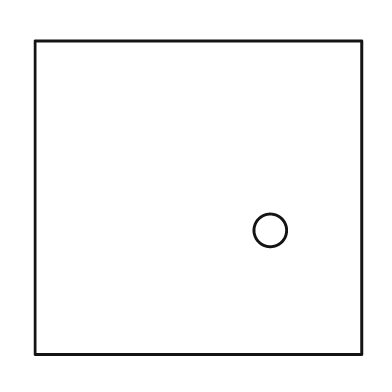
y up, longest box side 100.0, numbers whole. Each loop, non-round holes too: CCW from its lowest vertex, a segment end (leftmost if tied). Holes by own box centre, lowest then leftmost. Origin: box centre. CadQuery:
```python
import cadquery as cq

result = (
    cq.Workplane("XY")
    .moveTo(-50.0, -48.0)
    .lineTo(50.0, -48.0)
    .lineTo(50.0, 48.0)
    .lineTo(-50.0, 48.0)
    .close()
    .moveTo(22.0, -10.0)
    .circle(5.0)
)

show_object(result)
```